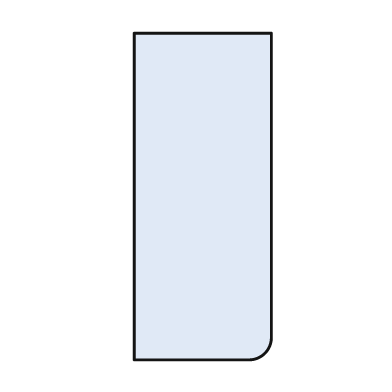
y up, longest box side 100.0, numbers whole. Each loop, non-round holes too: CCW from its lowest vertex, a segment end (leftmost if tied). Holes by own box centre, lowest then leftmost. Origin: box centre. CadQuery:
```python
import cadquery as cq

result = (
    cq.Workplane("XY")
    .moveTo(-21.0, -50.0)
    .lineTo(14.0, -50.0)
    .threePointArc((19.0, -48.0), (21.0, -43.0))
    .lineTo(21.0, 50.0)
    .lineTo(-21.0, 50.0)
    .close()
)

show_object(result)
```